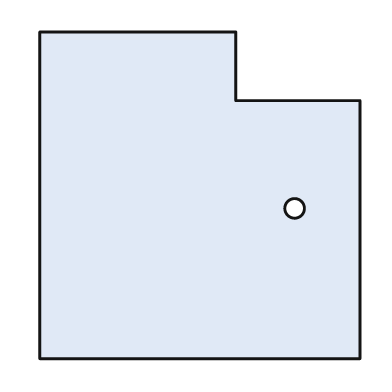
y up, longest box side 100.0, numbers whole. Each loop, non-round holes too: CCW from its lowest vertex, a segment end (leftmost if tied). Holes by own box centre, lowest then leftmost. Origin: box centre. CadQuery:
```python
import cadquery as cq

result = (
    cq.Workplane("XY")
    .moveTo(-49.0, -50.0)
    .lineTo(49.0, -50.0)
    .lineTo(49.0, 29.0)
    .lineTo(11.0, 29.0)
    .lineTo(11.0, 50.0)
    .lineTo(-49.0, 50.0)
    .close()
    .moveTo(29.0, -4.0)
    .circle(3.0)
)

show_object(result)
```